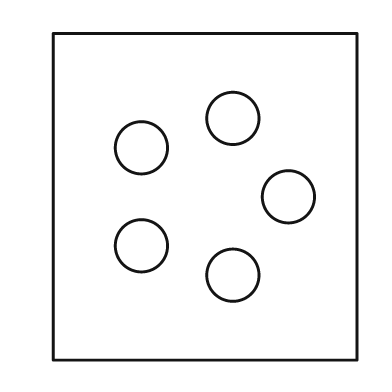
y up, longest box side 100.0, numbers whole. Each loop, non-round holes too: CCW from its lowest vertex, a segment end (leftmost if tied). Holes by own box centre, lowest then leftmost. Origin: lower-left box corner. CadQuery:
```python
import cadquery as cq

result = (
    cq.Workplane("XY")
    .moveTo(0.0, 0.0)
    .lineTo(93.0, 0.0)
    .lineTo(93.0, 100.0)
    .lineTo(0.0, 100.0)
    .close()
    .moveTo(55.0, 26.0)
    .circle(8.0)
    .moveTo(27.0, 35.0)
    .circle(8.0)
    .moveTo(72.0, 50.0)
    .circle(8.0)
    .moveTo(27.0, 65.0)
    .circle(8.0)
    .moveTo(55.0, 74.0)
    .circle(8.0)
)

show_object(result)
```